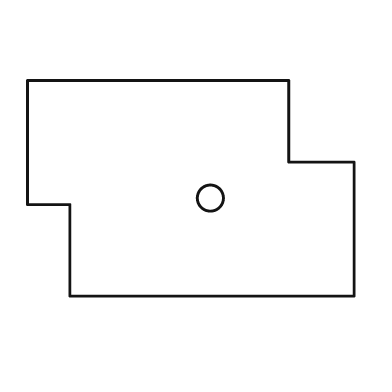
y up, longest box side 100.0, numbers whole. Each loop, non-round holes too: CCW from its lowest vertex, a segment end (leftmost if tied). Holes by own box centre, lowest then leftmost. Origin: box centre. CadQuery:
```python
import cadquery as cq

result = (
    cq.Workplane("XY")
    .moveTo(-37.0, -33.0)
    .lineTo(50.0, -33.0)
    .lineTo(50.0, 8.0)
    .lineTo(30.0, 8.0)
    .lineTo(30.0, 33.0)
    .lineTo(-50.0, 33.0)
    .lineTo(-50.0, -5.0)
    .lineTo(-37.0, -5.0)
    .close()
    .moveTo(6.0, -3.0)
    .circle(4.0)
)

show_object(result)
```